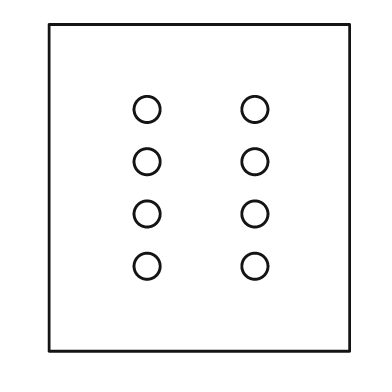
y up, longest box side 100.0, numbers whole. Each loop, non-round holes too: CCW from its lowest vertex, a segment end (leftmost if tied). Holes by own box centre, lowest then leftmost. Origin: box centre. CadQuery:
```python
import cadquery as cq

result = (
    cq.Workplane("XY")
    .moveTo(-46.0, -50.0)
    .lineTo(46.0, -50.0)
    .lineTo(46.0, 50.0)
    .lineTo(-46.0, 50.0)
    .close()
    .moveTo(-16.0, -24.0)
    .circle(4.0)
    .moveTo(17.0, -24.0)
    .circle(4.0)
    .moveTo(-16.0, -8.0)
    .circle(4.0)
    .moveTo(17.0, -8.0)
    .circle(4.0)
    .moveTo(-16.0, 8.0)
    .circle(4.0)
    .moveTo(17.0, 8.0)
    .circle(4.0)
    .moveTo(-16.0, 24.0)
    .circle(4.0)
    .moveTo(17.0, 24.0)
    .circle(4.0)
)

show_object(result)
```